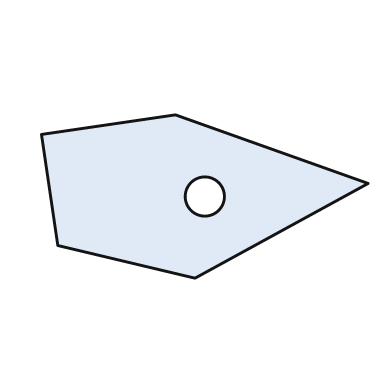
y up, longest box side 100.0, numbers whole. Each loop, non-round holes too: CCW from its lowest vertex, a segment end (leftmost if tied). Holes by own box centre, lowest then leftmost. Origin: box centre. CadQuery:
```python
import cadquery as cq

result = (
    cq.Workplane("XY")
    .moveTo(-3.0, -25.0)
    .lineTo(50.0, 4.0)
    .lineTo(-9.0, 25.0)
    .lineTo(-50.0, 19.0)
    .lineTo(-45.0, -15.0)
    .close()
    .moveTo(0.0, 0.0)
    .circle(6.0)
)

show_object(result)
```